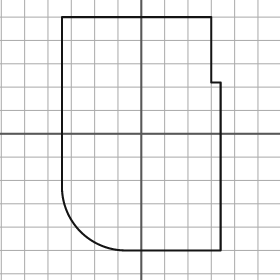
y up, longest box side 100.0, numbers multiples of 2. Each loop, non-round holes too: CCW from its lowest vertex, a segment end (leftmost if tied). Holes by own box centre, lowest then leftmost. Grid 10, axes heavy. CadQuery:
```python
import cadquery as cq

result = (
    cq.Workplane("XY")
    .moveTo(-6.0, -50.0)
    .lineTo(34.0, -50.0)
    .lineTo(34.0, 22.0)
    .lineTo(30.0, 22.0)
    .lineTo(30.0, 50.0)
    .lineTo(-34.0, 50.0)
    .lineTo(-34.0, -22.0)
    .threePointArc((-26.0, -42.0), (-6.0, -50.0))
    .close()
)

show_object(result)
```